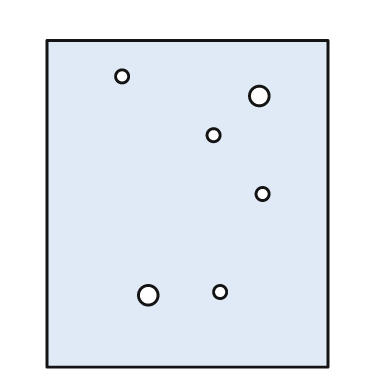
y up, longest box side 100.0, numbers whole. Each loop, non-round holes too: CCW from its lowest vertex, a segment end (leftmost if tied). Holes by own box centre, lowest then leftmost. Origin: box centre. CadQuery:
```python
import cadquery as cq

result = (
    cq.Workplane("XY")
    .moveTo(-43.0, -50.0)
    .lineTo(43.0, -50.0)
    .lineTo(43.0, 50.0)
    .lineTo(-43.0, 50.0)
    .close()
    .moveTo(-12.0, -28.0)
    .circle(3.0)
    .moveTo(10.0, -27.0)
    .circle(2.0)
    .moveTo(23.0, 3.0)
    .circle(2.0)
    .moveTo(8.0, 21.0)
    .circle(2.0)
    .moveTo(22.0, 33.0)
    .circle(3.0)
    .moveTo(-20.0, 39.0)
    .circle(2.0)
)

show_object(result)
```